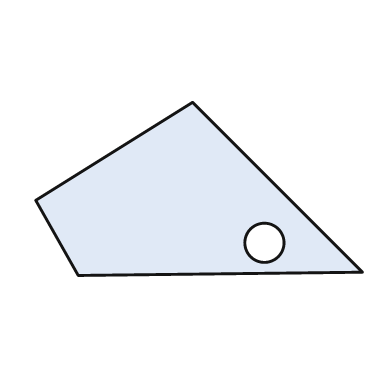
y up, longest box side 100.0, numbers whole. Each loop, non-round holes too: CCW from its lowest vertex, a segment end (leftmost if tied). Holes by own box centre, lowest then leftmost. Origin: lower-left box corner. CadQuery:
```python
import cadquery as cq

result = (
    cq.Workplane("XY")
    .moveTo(13.0, 0.0)
    .lineTo(100.0, 1.0)
    .lineTo(48.0, 53.0)
    .lineTo(0.0, 23.0)
    .close()
    .moveTo(70.0, 10.0)
    .circle(6.0)
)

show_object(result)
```